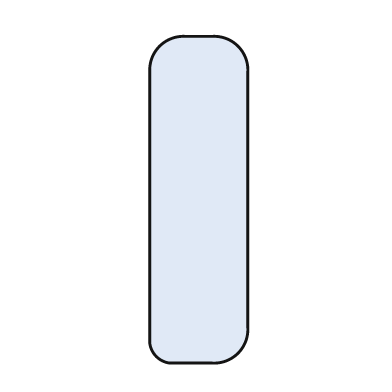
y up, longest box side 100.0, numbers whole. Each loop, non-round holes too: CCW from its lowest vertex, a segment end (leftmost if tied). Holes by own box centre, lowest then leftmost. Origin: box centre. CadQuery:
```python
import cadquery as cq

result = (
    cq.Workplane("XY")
    .moveTo(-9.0, -50.0)
    .lineTo(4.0, -50.0)
    .threePointArc((12.0, -47.0), (15.0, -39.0))
    .lineTo(15.0, 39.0)
    .threePointArc((12.0, 47.0), (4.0, 50.0))
    .lineTo(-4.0, 50.0)
    .threePointArc((-12.0, 47.0), (-15.0, 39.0))
    .lineTo(-15.0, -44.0)
    .threePointArc((-13.0, -48.0), (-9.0, -50.0))
    .close()
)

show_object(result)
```